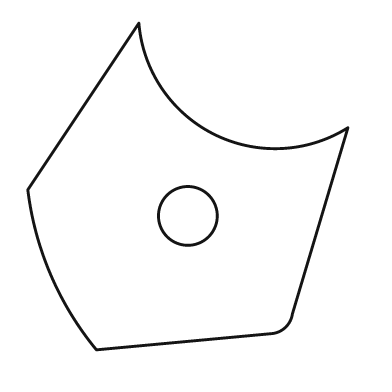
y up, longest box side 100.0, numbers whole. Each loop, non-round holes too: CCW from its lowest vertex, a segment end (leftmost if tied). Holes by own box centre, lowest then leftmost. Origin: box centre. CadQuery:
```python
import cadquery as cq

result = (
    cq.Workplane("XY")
    .moveTo(-28.0, -50.0)
    .lineTo(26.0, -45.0)
    .threePointArc((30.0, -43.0), (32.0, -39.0))
    .lineTo(49.0, 18.0)
    .threePointArc((8.0, 16.0), (-15.0, 50.0))
    .lineTo(-49.0, -1.0)
    .threePointArc((-42.0, -27.0), (-28.0, -50.0))
    .close()
    .moveTo(0.0, -9.0)
    .circle(9.0)
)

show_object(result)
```